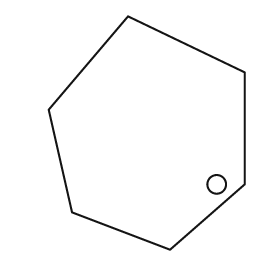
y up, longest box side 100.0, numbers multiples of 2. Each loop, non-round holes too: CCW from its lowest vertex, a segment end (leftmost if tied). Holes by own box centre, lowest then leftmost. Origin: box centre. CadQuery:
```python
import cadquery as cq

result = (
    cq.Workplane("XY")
    .moveTo(10.0, -50.0)
    .lineTo(42.0, -22.0)
    .lineTo(42.0, 26.0)
    .lineTo(-8.0, 50.0)
    .lineTo(-42.0, 10.0)
    .lineTo(-32.0, -34.0)
    .close()
    .moveTo(30.0, -22.0)
    .circle(4.0)
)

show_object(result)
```